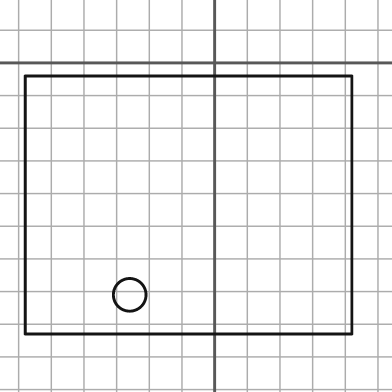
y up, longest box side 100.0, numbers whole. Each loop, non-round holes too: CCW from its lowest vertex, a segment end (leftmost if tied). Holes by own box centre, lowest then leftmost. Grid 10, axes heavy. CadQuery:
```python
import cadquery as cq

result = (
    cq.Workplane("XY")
    .moveTo(-58.0, -83.0)
    .lineTo(42.0, -83.0)
    .lineTo(42.0, -4.0)
    .lineTo(-58.0, -4.0)
    .close()
    .moveTo(-26.0, -71.0)
    .circle(5.0)
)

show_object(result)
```